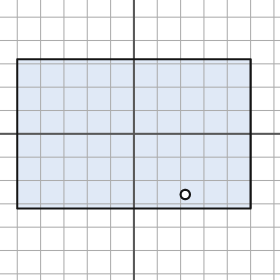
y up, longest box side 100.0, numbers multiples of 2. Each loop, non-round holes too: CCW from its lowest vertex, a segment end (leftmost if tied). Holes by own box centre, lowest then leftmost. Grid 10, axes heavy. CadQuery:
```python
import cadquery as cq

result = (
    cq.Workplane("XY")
    .moveTo(-50.0, -32.0)
    .lineTo(50.0, -32.0)
    .lineTo(50.0, 32.0)
    .lineTo(-50.0, 32.0)
    .close()
    .moveTo(22.0, -26.0)
    .circle(2.0)
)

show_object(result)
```